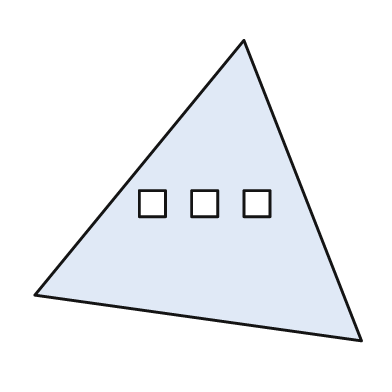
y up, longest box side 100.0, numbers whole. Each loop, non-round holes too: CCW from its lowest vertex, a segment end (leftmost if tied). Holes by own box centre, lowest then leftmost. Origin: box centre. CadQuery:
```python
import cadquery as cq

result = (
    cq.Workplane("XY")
    .moveTo(50.0, -46.0)
    .lineTo(14.0, 46.0)
    .lineTo(-50.0, -32.0)
    .close()
    .moveTo(-18.0, -8.0)
    .lineTo(-10.0, -8.0)
    .lineTo(-10.0, 0.0)
    .lineTo(-18.0, 0.0)
    .close()
    .moveTo(-2.0, -8.0)
    .lineTo(6.0, -8.0)
    .lineTo(6.0, 0.0)
    .lineTo(-2.0, 0.0)
    .close()
    .moveTo(14.0, -8.0)
    .lineTo(22.0, -8.0)
    .lineTo(22.0, 0.0)
    .lineTo(14.0, 0.0)
    .close()
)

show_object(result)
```